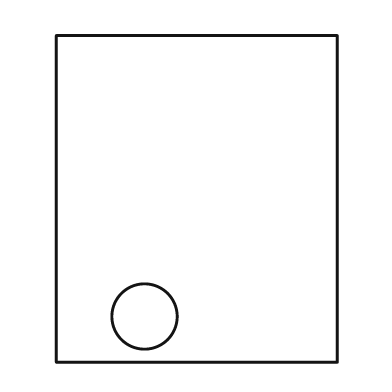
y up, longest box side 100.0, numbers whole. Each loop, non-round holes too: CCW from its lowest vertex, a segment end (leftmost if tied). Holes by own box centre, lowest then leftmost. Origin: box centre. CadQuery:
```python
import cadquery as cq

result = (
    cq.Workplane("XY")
    .moveTo(-43.0, -50.0)
    .lineTo(43.0, -50.0)
    .lineTo(43.0, 50.0)
    .lineTo(-43.0, 50.0)
    .close()
    .moveTo(-16.0, -36.0)
    .circle(10.0)
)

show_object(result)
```